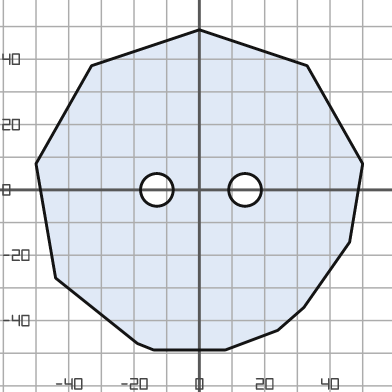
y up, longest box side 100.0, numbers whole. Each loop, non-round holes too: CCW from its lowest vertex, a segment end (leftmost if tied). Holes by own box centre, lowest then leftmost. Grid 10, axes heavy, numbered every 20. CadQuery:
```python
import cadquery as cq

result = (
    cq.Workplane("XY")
    .moveTo(-14.0, -49.0)
    .lineTo(8.0, -49.0)
    .lineTo(24.0, -43.0)
    .lineTo(32.0, -36.0)
    .lineTo(46.0, -16.0)
    .lineTo(50.0, 8.0)
    .lineTo(33.0, 38.0)
    .lineTo(0.0, 49.0)
    .lineTo(-33.0, 38.0)
    .lineTo(-50.0, 8.0)
    .lineTo(-44.0, -27.0)
    .lineTo(-19.0, -47.0)
    .close()
    .moveTo(-13.0, 0.0)
    .circle(5.0)
    .moveTo(14.0, 0.0)
    .circle(5.0)
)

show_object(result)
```